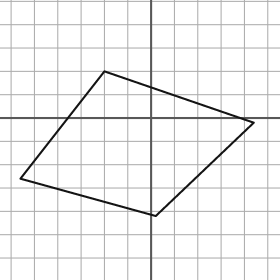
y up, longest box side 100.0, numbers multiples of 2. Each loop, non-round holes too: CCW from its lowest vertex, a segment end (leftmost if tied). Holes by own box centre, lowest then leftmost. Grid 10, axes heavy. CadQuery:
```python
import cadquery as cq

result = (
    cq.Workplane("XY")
    .moveTo(2.0, -42.0)
    .lineTo(44.0, -2.0)
    .lineTo(-20.0, 20.0)
    .lineTo(-56.0, -26.0)
    .close()
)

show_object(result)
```